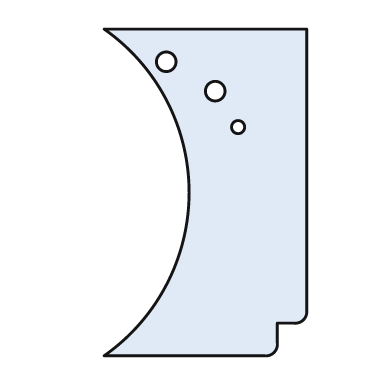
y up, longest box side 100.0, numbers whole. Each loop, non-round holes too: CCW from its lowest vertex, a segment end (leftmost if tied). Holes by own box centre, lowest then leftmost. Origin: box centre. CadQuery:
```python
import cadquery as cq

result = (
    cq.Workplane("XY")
    .moveTo(-31.0, -50.0)
    .lineTo(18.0, -50.0)
    .threePointArc((21.0, -49.0), (22.0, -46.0))
    .lineTo(22.0, -40.0)
    .lineTo(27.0, -40.0)
    .threePointArc((30.0, -39.0), (31.0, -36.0))
    .lineTo(31.0, 50.0)
    .lineTo(-31.0, 50.0)
    .threePointArc((-5.0, 0.0), (-31.0, -50.0))
    .close()
    .moveTo(10.0, 20.0)
    .circle(2.0)
    .moveTo(3.0, 31.0)
    .circle(3.0)
    .moveTo(-12.0, 40.0)
    .circle(3.0)
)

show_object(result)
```